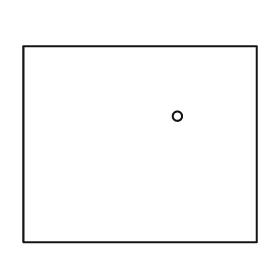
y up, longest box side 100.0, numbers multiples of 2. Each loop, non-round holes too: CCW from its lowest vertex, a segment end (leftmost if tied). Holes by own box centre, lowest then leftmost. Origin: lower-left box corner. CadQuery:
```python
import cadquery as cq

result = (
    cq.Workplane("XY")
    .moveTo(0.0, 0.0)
    .lineTo(100.0, 0.0)
    .lineTo(100.0, 84.0)
    .lineTo(0.0, 84.0)
    .close()
    .moveTo(66.0, 54.0)
    .circle(2.0)
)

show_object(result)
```